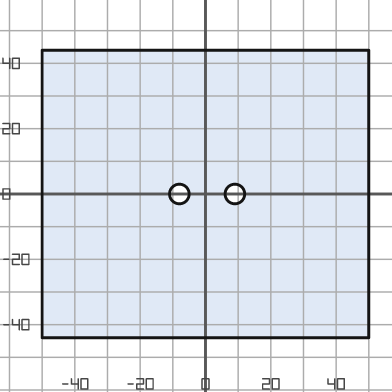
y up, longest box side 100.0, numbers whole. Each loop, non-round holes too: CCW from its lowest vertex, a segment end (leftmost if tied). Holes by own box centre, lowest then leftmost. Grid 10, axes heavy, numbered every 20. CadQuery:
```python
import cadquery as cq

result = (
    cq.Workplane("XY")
    .moveTo(-50.0, -44.0)
    .lineTo(50.0, -44.0)
    .lineTo(50.0, 44.0)
    .lineTo(-50.0, 44.0)
    .close()
    .moveTo(-8.0, 0.0)
    .circle(3.0)
    .moveTo(9.0, 0.0)
    .circle(3.0)
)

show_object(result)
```